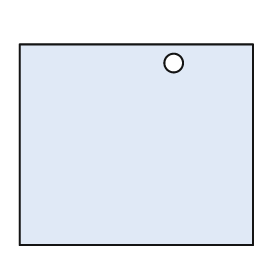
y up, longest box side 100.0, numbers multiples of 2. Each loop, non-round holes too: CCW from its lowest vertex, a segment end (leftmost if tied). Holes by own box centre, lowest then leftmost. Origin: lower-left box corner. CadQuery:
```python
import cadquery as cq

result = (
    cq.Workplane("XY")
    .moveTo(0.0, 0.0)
    .lineTo(100.0, 0.0)
    .lineTo(100.0, 86.0)
    .lineTo(0.0, 86.0)
    .close()
    .moveTo(66.0, 78.0)
    .circle(4.0)
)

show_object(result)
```